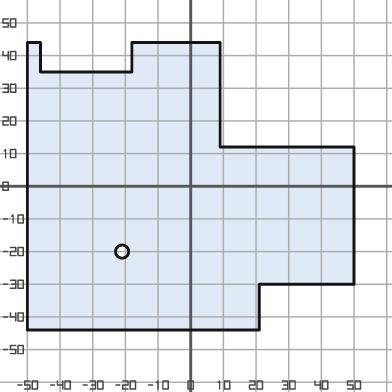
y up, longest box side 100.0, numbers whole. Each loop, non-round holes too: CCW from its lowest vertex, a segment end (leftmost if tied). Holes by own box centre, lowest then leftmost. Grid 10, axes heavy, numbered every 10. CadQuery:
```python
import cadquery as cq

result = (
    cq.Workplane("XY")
    .moveTo(-50.0, -44.0)
    .lineTo(21.0, -44.0)
    .lineTo(21.0, -30.0)
    .lineTo(50.0, -30.0)
    .lineTo(50.0, 12.0)
    .lineTo(9.0, 12.0)
    .lineTo(9.0, 44.0)
    .lineTo(-18.0, 44.0)
    .lineTo(-18.0, 35.0)
    .lineTo(-46.0, 35.0)
    .lineTo(-46.0, 44.0)
    .lineTo(-50.0, 44.0)
    .close()
    .moveTo(-21.0, -20.0)
    .circle(2.0)
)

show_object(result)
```